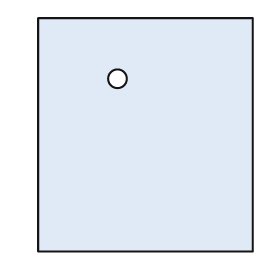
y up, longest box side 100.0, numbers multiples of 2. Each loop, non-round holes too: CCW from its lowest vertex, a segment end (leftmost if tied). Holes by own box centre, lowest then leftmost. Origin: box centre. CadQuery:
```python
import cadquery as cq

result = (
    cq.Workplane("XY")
    .moveTo(-46.0, -50.0)
    .lineTo(46.0, -50.0)
    .lineTo(46.0, 50.0)
    .lineTo(-46.0, 50.0)
    .close()
    .moveTo(-12.0, 24.0)
    .circle(4.0)
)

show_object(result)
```